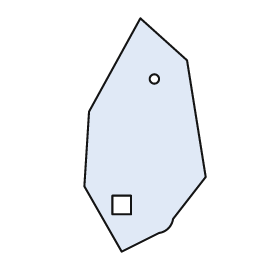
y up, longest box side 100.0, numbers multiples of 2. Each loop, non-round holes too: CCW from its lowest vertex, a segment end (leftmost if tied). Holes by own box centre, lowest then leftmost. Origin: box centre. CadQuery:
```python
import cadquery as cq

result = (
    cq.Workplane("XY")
    .moveTo(-10.0, -50.0)
    .lineTo(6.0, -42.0)
    .threePointArc((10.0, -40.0), (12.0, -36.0))
    .lineTo(26.0, -18.0)
    .lineTo(18.0, 32.0)
    .lineTo(-2.0, 50.0)
    .lineTo(-24.0, 10.0)
    .lineTo(-26.0, -22.0)
    .close()
    .moveTo(-14.0, -34.0)
    .lineTo(-6.0, -34.0)
    .lineTo(-6.0, -26.0)
    .lineTo(-14.0, -26.0)
    .close()
    .moveTo(4.0, 24.0)
    .circle(2.0)
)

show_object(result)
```